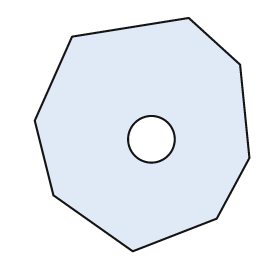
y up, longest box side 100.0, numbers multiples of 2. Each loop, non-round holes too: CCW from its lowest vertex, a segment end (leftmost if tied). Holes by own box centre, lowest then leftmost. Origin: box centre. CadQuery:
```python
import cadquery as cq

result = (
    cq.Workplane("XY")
    .moveTo(-4.0, -50.0)
    .lineTo(32.0, -36.0)
    .lineTo(46.0, -10.0)
    .lineTo(42.0, 30.0)
    .lineTo(20.0, 50.0)
    .lineTo(-30.0, 42.0)
    .lineTo(-46.0, 6.0)
    .lineTo(-38.0, -26.0)
    .close()
    .moveTo(4.0, -2.0)
    .circle(10.0)
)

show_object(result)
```